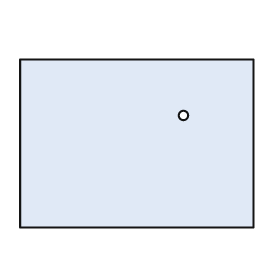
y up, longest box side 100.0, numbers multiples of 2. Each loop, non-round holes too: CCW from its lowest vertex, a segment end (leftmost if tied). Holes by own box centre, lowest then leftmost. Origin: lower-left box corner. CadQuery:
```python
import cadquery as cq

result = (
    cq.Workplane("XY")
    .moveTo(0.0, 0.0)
    .lineTo(100.0, 0.0)
    .lineTo(100.0, 72.0)
    .lineTo(0.0, 72.0)
    .close()
    .moveTo(70.0, 48.0)
    .circle(2.0)
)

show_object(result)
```